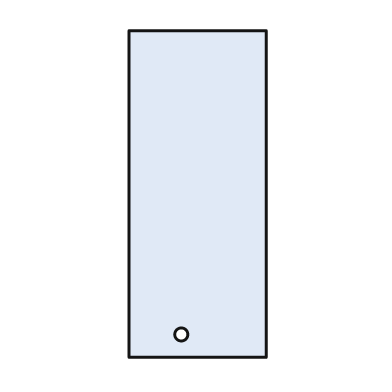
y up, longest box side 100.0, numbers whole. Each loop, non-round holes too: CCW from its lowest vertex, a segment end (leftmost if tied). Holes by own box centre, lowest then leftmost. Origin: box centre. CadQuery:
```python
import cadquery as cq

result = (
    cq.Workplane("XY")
    .moveTo(-21.0, -50.0)
    .lineTo(21.0, -50.0)
    .lineTo(21.0, 50.0)
    .lineTo(-21.0, 50.0)
    .close()
    .moveTo(-5.0, -43.0)
    .circle(2.0)
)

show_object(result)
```